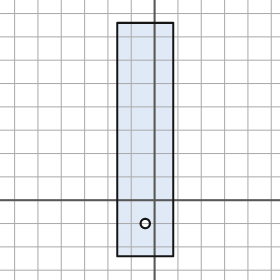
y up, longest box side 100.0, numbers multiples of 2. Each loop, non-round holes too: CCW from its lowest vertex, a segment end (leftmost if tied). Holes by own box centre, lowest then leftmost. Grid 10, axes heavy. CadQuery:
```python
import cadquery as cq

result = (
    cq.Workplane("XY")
    .moveTo(-16.0, -24.0)
    .lineTo(8.0, -24.0)
    .lineTo(8.0, 76.0)
    .lineTo(-16.0, 76.0)
    .close()
    .moveTo(-4.0, -10.0)
    .circle(2.0)
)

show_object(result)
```